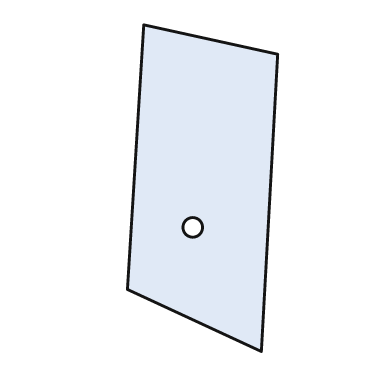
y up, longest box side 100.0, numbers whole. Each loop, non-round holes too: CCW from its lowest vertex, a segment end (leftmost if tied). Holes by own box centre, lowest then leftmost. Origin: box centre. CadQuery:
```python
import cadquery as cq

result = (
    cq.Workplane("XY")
    .moveTo(18.0, -50.0)
    .lineTo(23.0, 41.0)
    .lineTo(-18.0, 50.0)
    .lineTo(-23.0, -31.0)
    .close()
    .moveTo(-3.0, -12.0)
    .circle(3.0)
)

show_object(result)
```